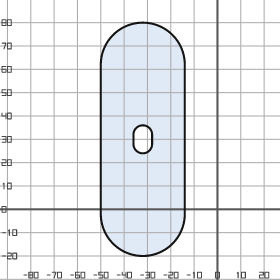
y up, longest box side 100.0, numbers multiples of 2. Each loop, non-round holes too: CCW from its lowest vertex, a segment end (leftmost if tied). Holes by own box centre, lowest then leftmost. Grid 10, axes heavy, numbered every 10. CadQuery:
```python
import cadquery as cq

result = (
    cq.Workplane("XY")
    .moveTo(-50.0, -2.0)
    .threePointArc((-32.0, -20.0), (-14.0, -2.0))
    .lineTo(-14.0, 62.0)
    .threePointArc((-32.0, 80.0), (-50.0, 62.0))
    .close()
    .moveTo(-36.0, 28.0)
    .threePointArc((-32.0, 24.0), (-28.0, 28.0))
    .lineTo(-28.0, 32.0)
    .threePointArc((-32.0, 36.0), (-36.0, 32.0))
    .close()
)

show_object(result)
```